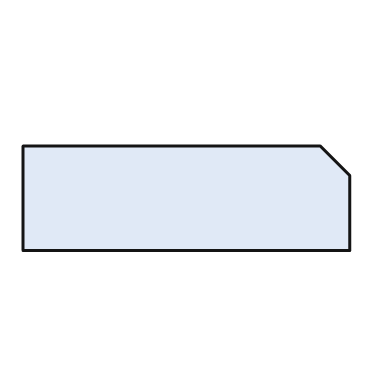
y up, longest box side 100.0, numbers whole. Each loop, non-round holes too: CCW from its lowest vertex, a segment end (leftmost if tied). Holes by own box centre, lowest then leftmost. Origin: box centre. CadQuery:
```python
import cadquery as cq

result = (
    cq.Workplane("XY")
    .moveTo(-50.0, -16.0)
    .lineTo(50.0, -16.0)
    .lineTo(50.0, 7.0)
    .lineTo(41.0, 16.0)
    .lineTo(-50.0, 16.0)
    .close()
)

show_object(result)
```